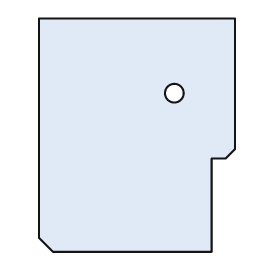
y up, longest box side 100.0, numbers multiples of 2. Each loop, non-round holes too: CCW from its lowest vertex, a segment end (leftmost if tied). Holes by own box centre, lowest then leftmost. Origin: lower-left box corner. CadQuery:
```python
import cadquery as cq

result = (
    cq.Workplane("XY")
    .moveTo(6.0, 0.0)
    .lineTo(74.0, 0.0)
    .lineTo(74.0, 40.0)
    .lineTo(80.0, 40.0)
    .lineTo(84.0, 44.0)
    .lineTo(84.0, 100.0)
    .lineTo(0.0, 100.0)
    .lineTo(0.0, 6.0)
    .close()
    .moveTo(58.0, 68.0)
    .circle(4.0)
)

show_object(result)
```